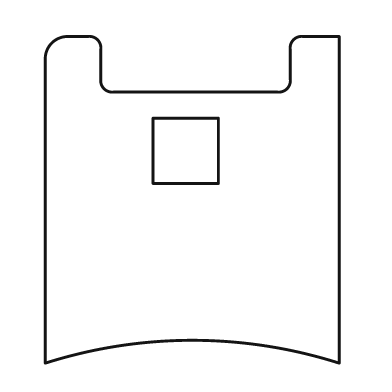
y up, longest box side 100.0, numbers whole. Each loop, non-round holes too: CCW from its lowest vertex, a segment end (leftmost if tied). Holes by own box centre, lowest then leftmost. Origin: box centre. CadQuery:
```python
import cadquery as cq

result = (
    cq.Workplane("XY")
    .moveTo(-45.0, -50.0)
    .threePointArc((0.0, -43.0), (45.0, -50.0))
    .lineTo(45.0, 50.0)
    .lineTo(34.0, 50.0)
    .threePointArc((31.0, 49.0), (30.0, 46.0))
    .lineTo(30.0, 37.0)
    .threePointArc((29.0, 34.0), (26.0, 33.0))
    .lineTo(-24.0, 33.0)
    .threePointArc((-27.0, 34.0), (-28.0, 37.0))
    .lineTo(-28.0, 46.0)
    .threePointArc((-29.0, 49.0), (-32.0, 50.0))
    .lineTo(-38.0, 50.0)
    .threePointArc((-43.0, 48.0), (-45.0, 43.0))
    .close()
    .moveTo(-12.0, 5.0)
    .lineTo(8.0, 5.0)
    .lineTo(8.0, 25.0)
    .lineTo(-12.0, 25.0)
    .close()
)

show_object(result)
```